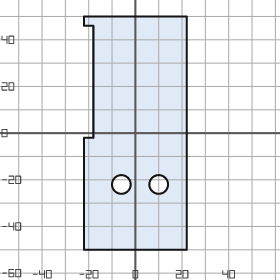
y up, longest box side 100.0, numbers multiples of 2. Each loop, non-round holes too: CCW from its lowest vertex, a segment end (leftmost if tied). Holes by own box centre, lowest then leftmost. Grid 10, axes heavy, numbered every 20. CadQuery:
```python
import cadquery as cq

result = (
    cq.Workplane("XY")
    .moveTo(-22.0, -50.0)
    .lineTo(22.0, -50.0)
    .lineTo(22.0, 50.0)
    .lineTo(-22.0, 50.0)
    .lineTo(-22.0, 46.0)
    .lineTo(-18.0, 46.0)
    .lineTo(-18.0, -2.0)
    .lineTo(-22.0, -2.0)
    .close()
    .moveTo(-6.0, -22.0)
    .circle(4.0)
    .moveTo(10.0, -22.0)
    .circle(4.0)
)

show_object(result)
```